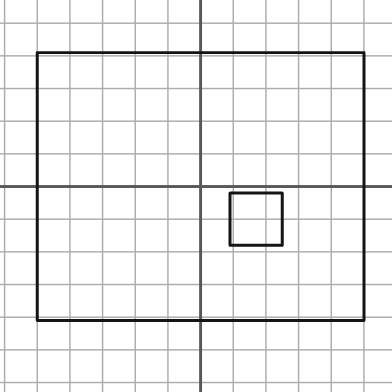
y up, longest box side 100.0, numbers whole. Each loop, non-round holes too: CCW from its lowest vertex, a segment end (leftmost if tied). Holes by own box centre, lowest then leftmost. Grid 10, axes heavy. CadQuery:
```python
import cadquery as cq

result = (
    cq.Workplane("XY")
    .moveTo(-50.0, -41.0)
    .lineTo(50.0, -41.0)
    .lineTo(50.0, 41.0)
    .lineTo(-50.0, 41.0)
    .close()
    .moveTo(9.0, -18.0)
    .lineTo(25.0, -18.0)
    .lineTo(25.0, -2.0)
    .lineTo(9.0, -2.0)
    .close()
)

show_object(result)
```